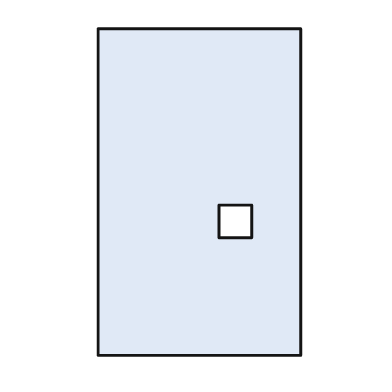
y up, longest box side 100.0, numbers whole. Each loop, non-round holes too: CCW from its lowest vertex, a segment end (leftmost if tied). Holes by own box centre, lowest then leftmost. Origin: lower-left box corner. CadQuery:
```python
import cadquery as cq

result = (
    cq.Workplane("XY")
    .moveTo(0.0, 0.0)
    .lineTo(62.0, 0.0)
    .lineTo(62.0, 100.0)
    .lineTo(0.0, 100.0)
    .close()
    .moveTo(37.0, 36.0)
    .lineTo(47.0, 36.0)
    .lineTo(47.0, 46.0)
    .lineTo(37.0, 46.0)
    .close()
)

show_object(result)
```